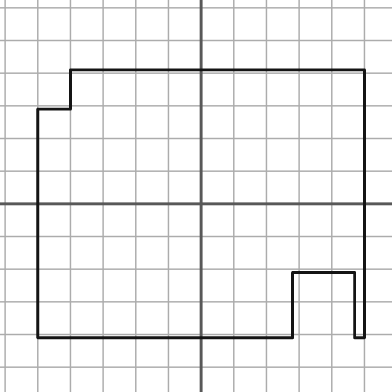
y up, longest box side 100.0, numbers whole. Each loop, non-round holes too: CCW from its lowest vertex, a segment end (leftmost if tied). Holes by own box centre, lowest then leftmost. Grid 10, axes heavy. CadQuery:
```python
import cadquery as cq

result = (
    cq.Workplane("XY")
    .moveTo(-50.0, -41.0)
    .lineTo(28.0, -41.0)
    .lineTo(28.0, -21.0)
    .lineTo(47.0, -21.0)
    .lineTo(47.0, -41.0)
    .lineTo(50.0, -41.0)
    .lineTo(50.0, 41.0)
    .lineTo(-40.0, 41.0)
    .lineTo(-40.0, 29.0)
    .lineTo(-50.0, 29.0)
    .close()
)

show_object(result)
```